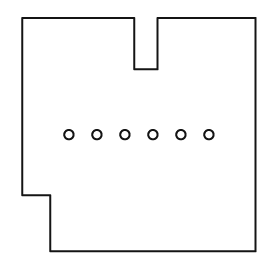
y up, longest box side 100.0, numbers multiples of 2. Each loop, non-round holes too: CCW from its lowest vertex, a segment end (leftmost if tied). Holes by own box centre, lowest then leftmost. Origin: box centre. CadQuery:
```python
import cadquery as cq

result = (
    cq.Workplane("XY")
    .moveTo(-38.0, -50.0)
    .lineTo(50.0, -50.0)
    .lineTo(50.0, 50.0)
    .lineTo(8.0, 50.0)
    .lineTo(8.0, 28.0)
    .lineTo(-2.0, 28.0)
    .lineTo(-2.0, 50.0)
    .lineTo(-50.0, 50.0)
    .lineTo(-50.0, -26.0)
    .lineTo(-38.0, -26.0)
    .close()
    .moveTo(-30.0, 0.0)
    .circle(2.0)
    .moveTo(-18.0, 0.0)
    .circle(2.0)
    .moveTo(-6.0, 0.0)
    .circle(2.0)
    .moveTo(6.0, 0.0)
    .circle(2.0)
    .moveTo(18.0, 0.0)
    .circle(2.0)
    .moveTo(30.0, 0.0)
    .circle(2.0)
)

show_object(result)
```